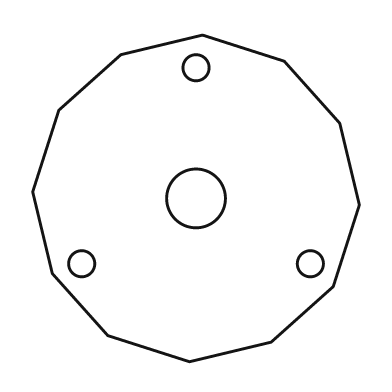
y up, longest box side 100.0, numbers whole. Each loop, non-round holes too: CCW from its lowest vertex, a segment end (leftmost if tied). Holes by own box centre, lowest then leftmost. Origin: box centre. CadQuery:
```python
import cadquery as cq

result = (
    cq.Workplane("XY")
    .moveTo(-2.0, -50.0)
    .lineTo(23.0, -44.0)
    .lineTo(42.0, -27.0)
    .lineTo(50.0, -2.0)
    .lineTo(44.0, 23.0)
    .lineTo(27.0, 42.0)
    .lineTo(2.0, 50.0)
    .lineTo(-23.0, 44.0)
    .lineTo(-42.0, 27.0)
    .lineTo(-50.0, 2.0)
    .lineTo(-44.0, -23.0)
    .lineTo(-27.0, -42.0)
    .close()
    .moveTo(-35.0, -20.0)
    .circle(4.0)
    .moveTo(35.0, -20.0)
    .circle(4.0)
    .moveTo(0.0, 0.0)
    .circle(9.0)
    .moveTo(0.0, 40.0)
    .circle(4.0)
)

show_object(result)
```